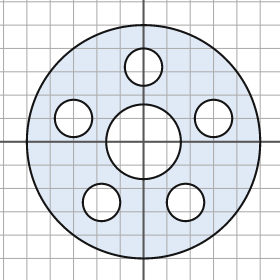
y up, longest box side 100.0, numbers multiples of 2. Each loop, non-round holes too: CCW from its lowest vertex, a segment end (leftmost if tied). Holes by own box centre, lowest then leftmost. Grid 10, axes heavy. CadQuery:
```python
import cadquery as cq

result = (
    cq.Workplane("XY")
    .moveTo(0.0, 0.0)
    .circle(50.0)
    .moveTo(-18.0, -26.0)
    .circle(8.0)
    .moveTo(18.0, -26.0)
    .circle(8.0)
    .moveTo(0.0, 0.0)
    .circle(16.0)
    .moveTo(-30.0, 10.0)
    .circle(8.0)
    .moveTo(30.0, 10.0)
    .circle(8.0)
    .moveTo(0.0, 32.0)
    .circle(8.0)
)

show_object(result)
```